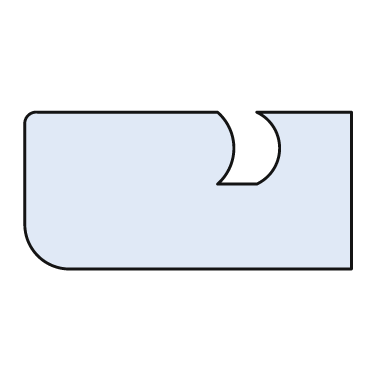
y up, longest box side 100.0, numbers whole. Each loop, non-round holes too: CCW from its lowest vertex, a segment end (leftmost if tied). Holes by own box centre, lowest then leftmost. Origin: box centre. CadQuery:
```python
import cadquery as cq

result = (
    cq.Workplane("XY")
    .moveTo(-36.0, -24.0)
    .lineTo(50.0, -24.0)
    .lineTo(50.0, 24.0)
    .lineTo(21.0, 24.0)
    .threePointArc((28.0, 13.0), (21.0, 2.0))
    .lineTo(9.0, 2.0)
    .threePointArc((14.0, 13.0), (9.0, 24.0))
    .lineTo(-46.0, 24.0)
    .threePointArc((-49.0, 23.0), (-50.0, 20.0))
    .lineTo(-50.0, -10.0)
    .threePointArc((-46.0, -20.0), (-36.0, -24.0))
    .close()
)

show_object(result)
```